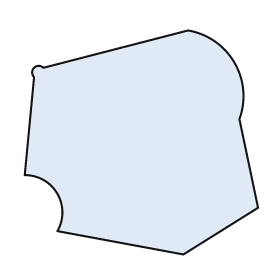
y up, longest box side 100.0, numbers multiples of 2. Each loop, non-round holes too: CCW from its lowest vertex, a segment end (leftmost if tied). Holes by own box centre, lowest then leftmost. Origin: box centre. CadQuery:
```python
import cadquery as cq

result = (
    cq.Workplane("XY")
    .moveTo(18.0, -48.0)
    .lineTo(50.0, -28.0)
    .lineTo(42.0, 10.0)
    .threePointArc((40.0, 34.0), (20.0, 48.0))
    .lineTo(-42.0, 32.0)
    .threePointArc((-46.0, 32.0), (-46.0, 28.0))
    .lineTo(-50.0, -14.0)
    .threePointArc((-36.0, -22.0), (-36.0, -38.0))
    .close()
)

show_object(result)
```